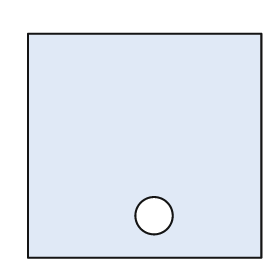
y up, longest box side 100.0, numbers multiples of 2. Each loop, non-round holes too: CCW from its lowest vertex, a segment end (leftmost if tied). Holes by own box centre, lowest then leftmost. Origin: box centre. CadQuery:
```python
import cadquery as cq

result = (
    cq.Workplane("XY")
    .moveTo(-50.0, -48.0)
    .lineTo(50.0, -48.0)
    .lineTo(50.0, 48.0)
    .lineTo(-50.0, 48.0)
    .close()
    .moveTo(4.0, -30.0)
    .circle(8.0)
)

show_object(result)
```